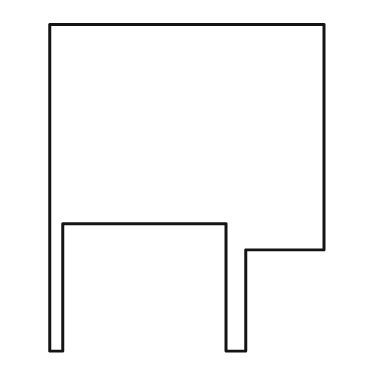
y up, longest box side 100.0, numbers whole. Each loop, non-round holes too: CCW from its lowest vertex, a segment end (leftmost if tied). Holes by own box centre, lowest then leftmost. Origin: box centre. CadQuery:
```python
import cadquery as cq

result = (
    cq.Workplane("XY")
    .moveTo(-42.0, -50.0)
    .lineTo(-38.0, -50.0)
    .lineTo(-38.0, -11.0)
    .lineTo(12.0, -11.0)
    .lineTo(12.0, -50.0)
    .lineTo(18.0, -50.0)
    .lineTo(18.0, -19.0)
    .lineTo(42.0, -19.0)
    .lineTo(42.0, 50.0)
    .lineTo(-42.0, 50.0)
    .close()
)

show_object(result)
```